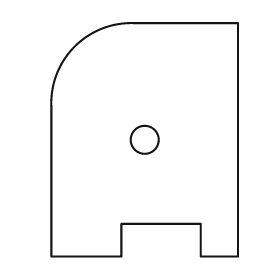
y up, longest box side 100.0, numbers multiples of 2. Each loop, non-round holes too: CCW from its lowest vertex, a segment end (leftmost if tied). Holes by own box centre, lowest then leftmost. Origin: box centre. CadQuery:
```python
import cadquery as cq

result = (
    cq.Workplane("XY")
    .moveTo(-40.0, -50.0)
    .lineTo(-10.0, -50.0)
    .lineTo(-10.0, -36.0)
    .lineTo(24.0, -36.0)
    .lineTo(24.0, -50.0)
    .lineTo(40.0, -50.0)
    .lineTo(40.0, 50.0)
    .lineTo(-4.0, 50.0)
    .threePointArc((-30.0, 40.0), (-40.0, 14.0))
    .close()
    .moveTo(0.0, 0.0)
    .circle(6.0)
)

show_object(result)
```